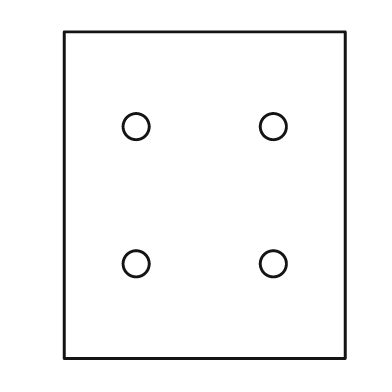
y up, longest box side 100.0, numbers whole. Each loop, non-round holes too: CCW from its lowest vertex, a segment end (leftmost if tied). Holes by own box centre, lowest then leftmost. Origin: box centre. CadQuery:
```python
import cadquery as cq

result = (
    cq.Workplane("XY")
    .moveTo(-43.0, -50.0)
    .lineTo(43.0, -50.0)
    .lineTo(43.0, 50.0)
    .lineTo(-43.0, 50.0)
    .close()
    .moveTo(-21.0, -21.0)
    .circle(4.0)
    .moveTo(21.0, -21.0)
    .circle(4.0)
    .moveTo(-21.0, 21.0)
    .circle(4.0)
    .moveTo(21.0, 21.0)
    .circle(4.0)
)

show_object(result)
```